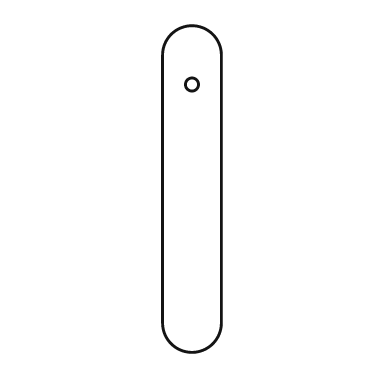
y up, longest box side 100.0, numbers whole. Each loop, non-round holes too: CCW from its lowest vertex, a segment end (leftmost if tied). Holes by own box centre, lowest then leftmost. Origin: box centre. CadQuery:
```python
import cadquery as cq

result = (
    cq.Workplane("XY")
    .moveTo(-9.0, -41.0)
    .threePointArc((0.0, -50.0), (9.0, -41.0))
    .lineTo(9.0, 41.0)
    .threePointArc((0.0, 50.0), (-9.0, 41.0))
    .close()
    .moveTo(0.0, 32.0)
    .circle(2.0)
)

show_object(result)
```